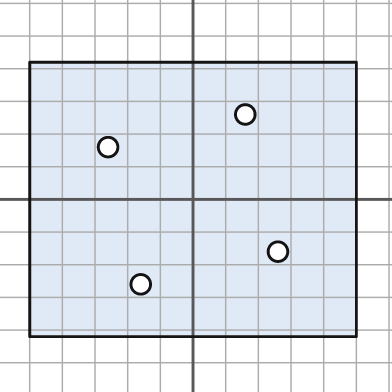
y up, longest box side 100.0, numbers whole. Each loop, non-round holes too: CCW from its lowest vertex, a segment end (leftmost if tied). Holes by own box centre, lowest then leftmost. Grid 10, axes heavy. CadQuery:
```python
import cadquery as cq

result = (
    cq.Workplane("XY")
    .moveTo(-50.0, -42.0)
    .lineTo(50.0, -42.0)
    .lineTo(50.0, 42.0)
    .lineTo(-50.0, 42.0)
    .close()
    .moveTo(-16.0, -26.0)
    .circle(3.0)
    .moveTo(26.0, -16.0)
    .circle(3.0)
    .moveTo(-26.0, 16.0)
    .circle(3.0)
    .moveTo(16.0, 26.0)
    .circle(3.0)
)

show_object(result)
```